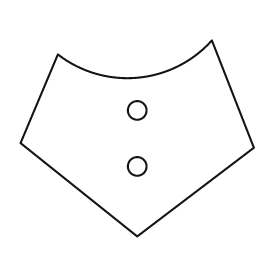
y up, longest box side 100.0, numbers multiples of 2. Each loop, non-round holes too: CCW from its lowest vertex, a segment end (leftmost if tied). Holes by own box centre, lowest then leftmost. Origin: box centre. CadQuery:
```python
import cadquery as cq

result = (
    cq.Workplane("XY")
    .moveTo(0.0, -42.0)
    .lineTo(50.0, -4.0)
    .lineTo(32.0, 42.0)
    .threePointArc((0.0, 26.0), (-34.0, 36.0))
    .lineTo(-50.0, -2.0)
    .close()
    .moveTo(0.0, -12.0)
    .circle(4.0)
    .moveTo(0.0, 12.0)
    .circle(4.0)
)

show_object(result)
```